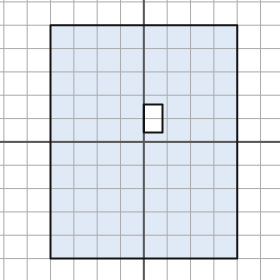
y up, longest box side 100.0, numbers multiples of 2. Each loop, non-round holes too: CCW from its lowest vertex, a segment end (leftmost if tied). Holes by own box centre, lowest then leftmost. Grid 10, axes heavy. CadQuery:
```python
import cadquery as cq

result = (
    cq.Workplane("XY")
    .moveTo(-40.0, -50.0)
    .lineTo(40.0, -50.0)
    .lineTo(40.0, 50.0)
    .lineTo(-40.0, 50.0)
    .close()
    .moveTo(0.0, 4.0)
    .lineTo(8.0, 4.0)
    .lineTo(8.0, 16.0)
    .lineTo(0.0, 16.0)
    .close()
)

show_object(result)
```